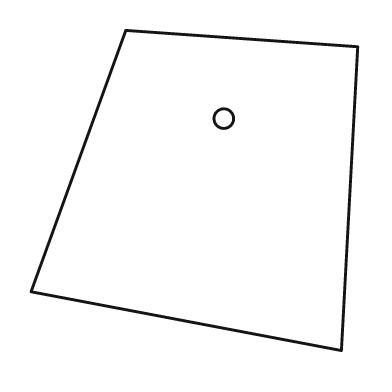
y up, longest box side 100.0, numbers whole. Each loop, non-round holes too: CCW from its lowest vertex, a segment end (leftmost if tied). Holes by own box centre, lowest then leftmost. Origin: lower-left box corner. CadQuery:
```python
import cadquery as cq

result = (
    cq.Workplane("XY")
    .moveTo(95.0, 0.0)
    .lineTo(100.0, 93.0)
    .lineTo(29.0, 98.0)
    .lineTo(0.0, 18.0)
    .close()
    .moveTo(59.0, 71.0)
    .circle(3.0)
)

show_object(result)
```